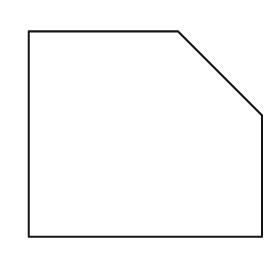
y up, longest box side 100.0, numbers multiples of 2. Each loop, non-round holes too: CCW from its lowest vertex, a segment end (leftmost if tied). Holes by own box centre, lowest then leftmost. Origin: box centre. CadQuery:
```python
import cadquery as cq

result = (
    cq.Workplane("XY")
    .moveTo(-50.0, -44.0)
    .lineTo(50.0, -44.0)
    .lineTo(50.0, 8.0)
    .lineTo(14.0, 44.0)
    .lineTo(-50.0, 44.0)
    .close()
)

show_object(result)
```